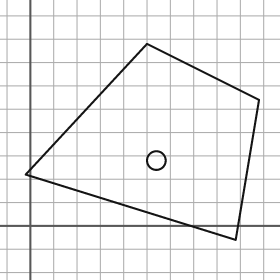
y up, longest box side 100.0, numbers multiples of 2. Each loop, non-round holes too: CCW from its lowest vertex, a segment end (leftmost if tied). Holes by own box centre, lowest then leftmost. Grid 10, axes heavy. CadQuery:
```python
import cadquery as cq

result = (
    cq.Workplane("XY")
    .moveTo(88.0, -6.0)
    .lineTo(98.0, 54.0)
    .lineTo(50.0, 78.0)
    .lineTo(-2.0, 22.0)
    .close()
    .moveTo(54.0, 28.0)
    .circle(4.0)
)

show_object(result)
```